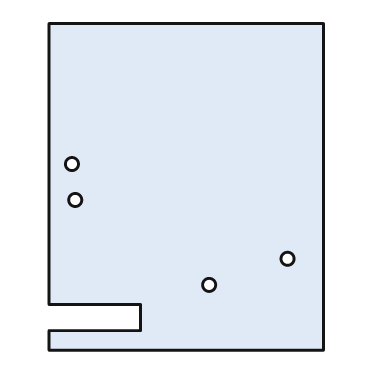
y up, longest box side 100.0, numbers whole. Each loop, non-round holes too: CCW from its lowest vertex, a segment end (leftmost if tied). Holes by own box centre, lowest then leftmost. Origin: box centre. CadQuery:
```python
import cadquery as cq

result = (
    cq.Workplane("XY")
    .moveTo(-42.0, -50.0)
    .lineTo(42.0, -50.0)
    .lineTo(42.0, 50.0)
    .lineTo(-42.0, 50.0)
    .lineTo(-42.0, -36.0)
    .lineTo(-14.0, -36.0)
    .lineTo(-14.0, -44.0)
    .lineTo(-42.0, -44.0)
    .close()
    .moveTo(7.0, -30.0)
    .circle(2.0)
    .moveTo(31.0, -22.0)
    .circle(2.0)
    .moveTo(-34.0, -4.0)
    .circle(2.0)
    .moveTo(-35.0, 7.0)
    .circle(2.0)
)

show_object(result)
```